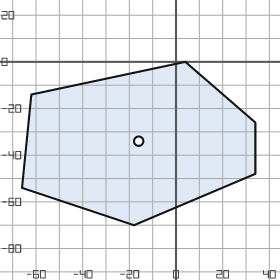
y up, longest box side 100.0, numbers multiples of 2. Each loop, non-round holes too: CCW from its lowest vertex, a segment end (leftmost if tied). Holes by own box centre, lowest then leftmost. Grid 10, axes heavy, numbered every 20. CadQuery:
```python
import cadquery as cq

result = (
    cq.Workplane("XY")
    .moveTo(-18.0, -70.0)
    .lineTo(34.0, -48.0)
    .lineTo(34.0, -26.0)
    .lineTo(4.0, 0.0)
    .lineTo(-62.0, -14.0)
    .lineTo(-66.0, -54.0)
    .close()
    .moveTo(-16.0, -34.0)
    .circle(2.0)
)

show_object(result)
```